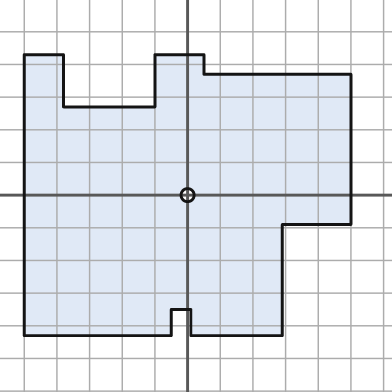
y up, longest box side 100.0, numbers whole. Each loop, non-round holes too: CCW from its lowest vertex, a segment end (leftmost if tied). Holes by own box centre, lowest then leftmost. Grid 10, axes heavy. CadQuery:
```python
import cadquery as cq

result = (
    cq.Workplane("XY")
    .moveTo(-50.0, -43.0)
    .lineTo(-5.0, -43.0)
    .lineTo(-5.0, -35.0)
    .lineTo(1.0, -35.0)
    .lineTo(1.0, -43.0)
    .lineTo(29.0, -43.0)
    .lineTo(29.0, -9.0)
    .lineTo(50.0, -9.0)
    .lineTo(50.0, 37.0)
    .lineTo(5.0, 37.0)
    .lineTo(5.0, 43.0)
    .lineTo(-10.0, 43.0)
    .lineTo(-10.0, 27.0)
    .lineTo(-38.0, 27.0)
    .lineTo(-38.0, 43.0)
    .lineTo(-50.0, 43.0)
    .close()
    .moveTo(0.0, 0.0)
    .circle(2.0)
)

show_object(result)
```